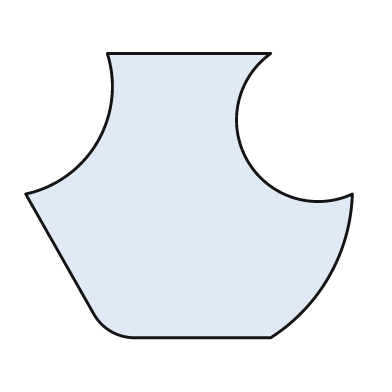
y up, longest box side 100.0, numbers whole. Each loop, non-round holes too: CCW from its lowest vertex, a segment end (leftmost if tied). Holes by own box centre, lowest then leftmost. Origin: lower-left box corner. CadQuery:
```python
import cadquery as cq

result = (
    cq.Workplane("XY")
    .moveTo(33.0, 0.0)
    .lineTo(75.0, 0.0)
    .threePointArc((93.0, 19.0), (100.0, 44.0))
    .threePointArc((68.0, 54.0), (75.0, 87.0))
    .lineTo(25.0, 87.0)
    .threePointArc((22.0, 60.0), (0.0, 44.0))
    .lineTo(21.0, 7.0)
    .threePointArc((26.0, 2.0), (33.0, 0.0))
    .close()
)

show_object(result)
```